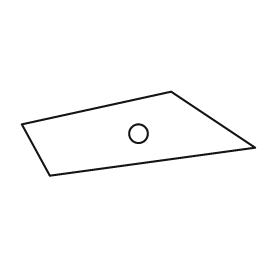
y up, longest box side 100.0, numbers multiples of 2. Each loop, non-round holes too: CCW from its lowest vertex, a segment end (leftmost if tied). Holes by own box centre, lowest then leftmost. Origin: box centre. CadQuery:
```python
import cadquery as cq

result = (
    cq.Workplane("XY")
    .moveTo(-38.0, -18.0)
    .lineTo(50.0, -6.0)
    .lineTo(14.0, 18.0)
    .lineTo(-50.0, 4.0)
    .close()
    .moveTo(0.0, 0.0)
    .circle(4.0)
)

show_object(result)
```